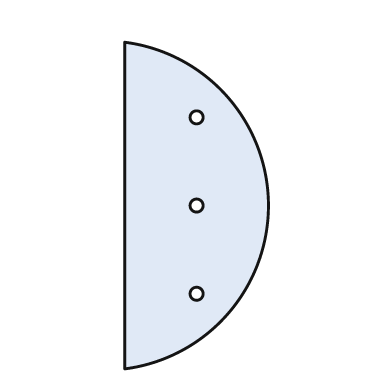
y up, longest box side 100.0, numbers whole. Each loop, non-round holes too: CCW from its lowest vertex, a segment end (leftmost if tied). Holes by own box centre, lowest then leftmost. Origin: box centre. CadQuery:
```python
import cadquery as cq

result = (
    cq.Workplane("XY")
    .moveTo(-22.0, -50.0)
    .threePointArc((22.0, 0.0), (-22.0, 50.0))
    .close()
    .moveTo(0.0, -27.0)
    .circle(2.0)
    .moveTo(0.0, 0.0)
    .circle(2.0)
    .moveTo(0.0, 27.0)
    .circle(2.0)
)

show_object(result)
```